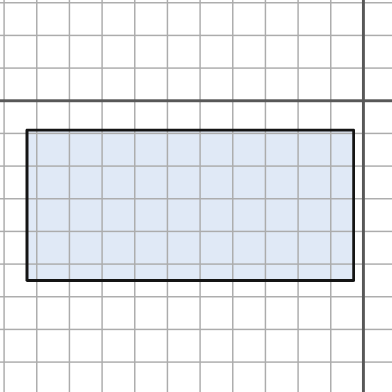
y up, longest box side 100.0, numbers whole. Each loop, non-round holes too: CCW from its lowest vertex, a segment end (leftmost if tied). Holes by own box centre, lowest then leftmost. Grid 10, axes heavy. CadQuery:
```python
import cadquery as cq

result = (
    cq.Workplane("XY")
    .moveTo(-103.0, -55.0)
    .lineTo(-3.0, -55.0)
    .lineTo(-3.0, -9.0)
    .lineTo(-103.0, -9.0)
    .close()
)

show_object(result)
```